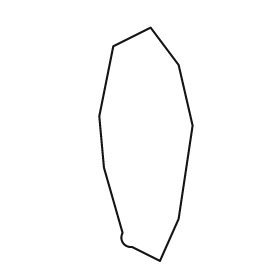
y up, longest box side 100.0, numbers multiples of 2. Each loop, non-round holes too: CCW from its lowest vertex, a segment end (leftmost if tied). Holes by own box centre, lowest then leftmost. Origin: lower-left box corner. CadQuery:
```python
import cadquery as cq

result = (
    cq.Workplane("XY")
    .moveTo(26.0, 0.0)
    .lineTo(34.0, 18.0)
    .lineTo(40.0, 58.0)
    .lineTo(34.0, 84.0)
    .lineTo(22.0, 100.0)
    .lineTo(6.0, 92.0)
    .lineTo(0.0, 62.0)
    .lineTo(2.0, 40.0)
    .lineTo(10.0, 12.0)
    .threePointArc((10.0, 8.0), (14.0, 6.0))
    .close()
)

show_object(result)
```